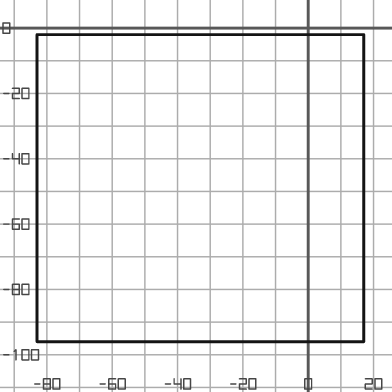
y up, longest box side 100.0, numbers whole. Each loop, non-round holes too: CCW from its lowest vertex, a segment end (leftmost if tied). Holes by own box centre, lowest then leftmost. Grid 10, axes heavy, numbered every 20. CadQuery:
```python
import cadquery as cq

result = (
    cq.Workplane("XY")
    .moveTo(-83.0, -96.0)
    .lineTo(17.0, -96.0)
    .lineTo(17.0, -2.0)
    .lineTo(-83.0, -2.0)
    .close()
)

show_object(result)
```